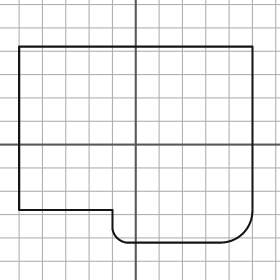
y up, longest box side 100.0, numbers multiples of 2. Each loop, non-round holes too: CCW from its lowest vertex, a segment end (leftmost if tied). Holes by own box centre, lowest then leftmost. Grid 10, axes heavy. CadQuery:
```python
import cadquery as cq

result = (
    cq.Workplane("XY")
    .moveTo(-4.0, -42.0)
    .lineTo(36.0, -42.0)
    .threePointArc((46.0, -38.0), (50.0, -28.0))
    .lineTo(50.0, 42.0)
    .lineTo(-50.0, 42.0)
    .lineTo(-50.0, -28.0)
    .lineTo(-10.0, -28.0)
    .lineTo(-10.0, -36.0)
    .threePointArc((-8.0, -40.0), (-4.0, -42.0))
    .close()
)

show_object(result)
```